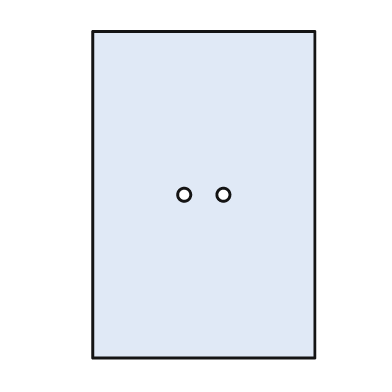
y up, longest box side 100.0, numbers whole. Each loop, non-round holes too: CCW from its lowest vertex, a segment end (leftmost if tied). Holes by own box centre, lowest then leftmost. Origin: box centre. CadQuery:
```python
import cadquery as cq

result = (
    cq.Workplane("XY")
    .moveTo(-34.0, -50.0)
    .lineTo(34.0, -50.0)
    .lineTo(34.0, 50.0)
    .lineTo(-34.0, 50.0)
    .close()
    .moveTo(-6.0, 0.0)
    .circle(2.0)
    .moveTo(6.0, 0.0)
    .circle(2.0)
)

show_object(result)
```